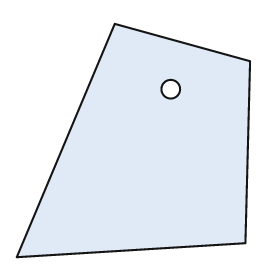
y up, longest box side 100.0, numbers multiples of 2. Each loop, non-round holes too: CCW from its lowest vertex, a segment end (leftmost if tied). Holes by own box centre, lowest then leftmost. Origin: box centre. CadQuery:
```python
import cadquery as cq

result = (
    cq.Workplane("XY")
    .moveTo(-50.0, -50.0)
    .lineTo(48.0, -44.0)
    .lineTo(50.0, 34.0)
    .lineTo(-8.0, 50.0)
    .close()
    .moveTo(16.0, 22.0)
    .circle(4.0)
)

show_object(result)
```